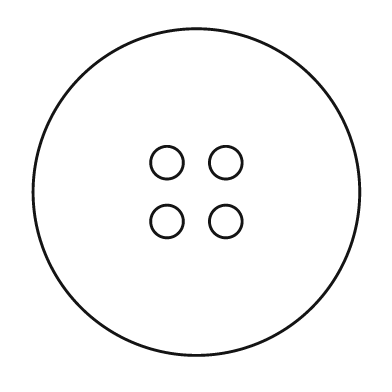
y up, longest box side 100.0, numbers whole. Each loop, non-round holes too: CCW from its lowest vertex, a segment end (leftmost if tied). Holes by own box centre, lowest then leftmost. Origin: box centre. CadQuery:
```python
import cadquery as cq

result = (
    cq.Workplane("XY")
    .moveTo(0.0, 0.0)
    .circle(50.0)
    .moveTo(-9.0, -9.0)
    .circle(5.0)
    .moveTo(9.0, -9.0)
    .circle(5.0)
    .moveTo(-9.0, 9.0)
    .circle(5.0)
    .moveTo(9.0, 9.0)
    .circle(5.0)
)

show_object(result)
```